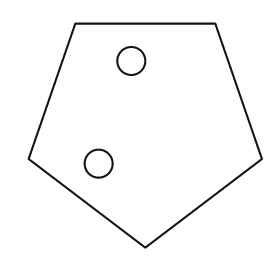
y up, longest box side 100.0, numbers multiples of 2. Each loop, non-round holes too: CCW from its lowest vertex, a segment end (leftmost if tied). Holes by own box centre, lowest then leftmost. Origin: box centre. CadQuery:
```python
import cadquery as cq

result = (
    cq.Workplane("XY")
    .moveTo(0.0, -48.0)
    .lineTo(50.0, -10.0)
    .lineTo(30.0, 48.0)
    .lineTo(-30.0, 48.0)
    .lineTo(-50.0, -10.0)
    .close()
    .moveTo(-20.0, -12.0)
    .circle(6.0)
    .moveTo(-6.0, 32.0)
    .circle(6.0)
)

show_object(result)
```